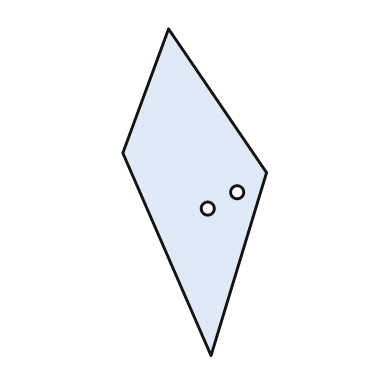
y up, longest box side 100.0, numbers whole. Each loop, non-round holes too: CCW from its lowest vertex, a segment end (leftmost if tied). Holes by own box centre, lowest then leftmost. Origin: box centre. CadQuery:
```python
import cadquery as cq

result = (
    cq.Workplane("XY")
    .moveTo(5.0, -50.0)
    .lineTo(22.0, 6.0)
    .lineTo(-8.0, 50.0)
    .lineTo(-22.0, 12.0)
    .close()
    .moveTo(4.0, -5.0)
    .circle(2.0)
    .moveTo(13.0, 0.0)
    .circle(2.0)
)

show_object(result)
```